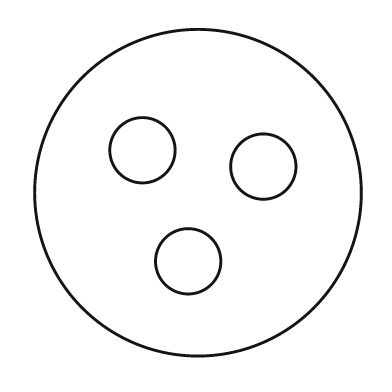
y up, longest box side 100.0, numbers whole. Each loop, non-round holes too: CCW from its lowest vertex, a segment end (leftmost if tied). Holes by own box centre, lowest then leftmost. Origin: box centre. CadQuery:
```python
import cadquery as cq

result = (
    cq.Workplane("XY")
    .moveTo(0.0, 0.0)
    .circle(50.0)
    .moveTo(-3.0, -21.0)
    .circle(10.0)
    .moveTo(20.0, 8.0)
    .circle(10.0)
    .moveTo(-17.0, 13.0)
    .circle(10.0)
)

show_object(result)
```